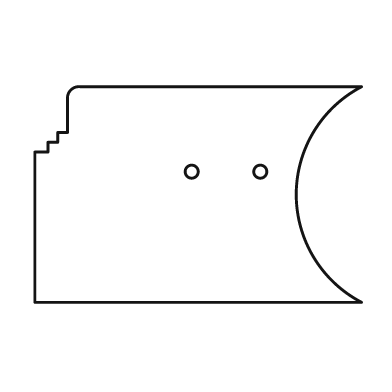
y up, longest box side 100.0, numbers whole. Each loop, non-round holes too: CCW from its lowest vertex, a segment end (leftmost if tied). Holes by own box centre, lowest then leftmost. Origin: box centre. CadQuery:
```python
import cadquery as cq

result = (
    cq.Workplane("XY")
    .moveTo(-50.0, -33.0)
    .lineTo(50.0, -33.0)
    .threePointArc((30.0, 0.0), (50.0, 33.0))
    .lineTo(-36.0, 33.0)
    .threePointArc((-39.0, 32.0), (-40.0, 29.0))
    .lineTo(-40.0, 19.0)
    .lineTo(-43.0, 19.0)
    .lineTo(-43.0, 16.0)
    .lineTo(-46.0, 16.0)
    .lineTo(-46.0, 13.0)
    .lineTo(-50.0, 13.0)
    .close()
    .moveTo(-2.0, 7.0)
    .circle(2.0)
    .moveTo(19.0, 7.0)
    .circle(2.0)
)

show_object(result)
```